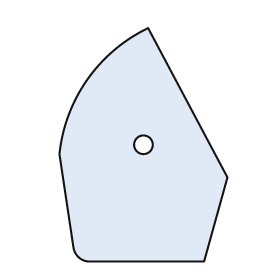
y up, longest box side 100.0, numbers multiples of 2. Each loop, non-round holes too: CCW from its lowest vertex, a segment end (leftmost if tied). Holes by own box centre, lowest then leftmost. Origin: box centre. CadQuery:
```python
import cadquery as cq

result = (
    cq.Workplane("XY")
    .moveTo(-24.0, -50.0)
    .lineTo(26.0, -50.0)
    .lineTo(36.0, -14.0)
    .lineTo(2.0, 50.0)
    .threePointArc((-24.0, 28.0), (-36.0, -4.0))
    .lineTo(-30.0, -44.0)
    .threePointArc((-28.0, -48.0), (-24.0, -50.0))
    .close()
    .moveTo(0.0, 0.0)
    .circle(4.0)
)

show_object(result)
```